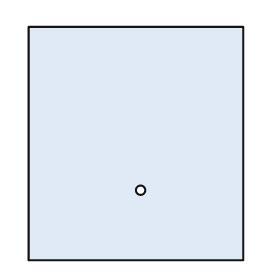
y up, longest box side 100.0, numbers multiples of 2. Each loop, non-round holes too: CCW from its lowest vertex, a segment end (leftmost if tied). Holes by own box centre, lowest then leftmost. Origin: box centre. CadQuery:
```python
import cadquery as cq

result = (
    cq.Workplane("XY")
    .moveTo(-46.0, -50.0)
    .lineTo(46.0, -50.0)
    .lineTo(46.0, 50.0)
    .lineTo(-46.0, 50.0)
    .close()
    .moveTo(2.0, -20.0)
    .circle(2.0)
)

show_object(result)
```